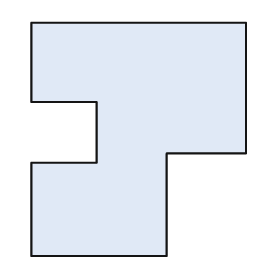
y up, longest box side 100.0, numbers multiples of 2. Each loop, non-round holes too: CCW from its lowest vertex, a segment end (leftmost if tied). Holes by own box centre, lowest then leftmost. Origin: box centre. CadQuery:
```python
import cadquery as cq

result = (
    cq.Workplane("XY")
    .moveTo(-46.0, -50.0)
    .lineTo(12.0, -50.0)
    .lineTo(12.0, -6.0)
    .lineTo(46.0, -6.0)
    .lineTo(46.0, 50.0)
    .lineTo(-46.0, 50.0)
    .lineTo(-46.0, 16.0)
    .lineTo(-18.0, 16.0)
    .lineTo(-18.0, -10.0)
    .lineTo(-46.0, -10.0)
    .close()
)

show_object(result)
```